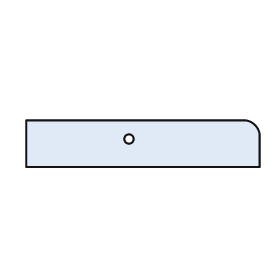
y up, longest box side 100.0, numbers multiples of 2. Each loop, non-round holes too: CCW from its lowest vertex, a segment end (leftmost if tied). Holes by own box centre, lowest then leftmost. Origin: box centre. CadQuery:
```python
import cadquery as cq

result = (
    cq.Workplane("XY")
    .moveTo(-50.0, -10.0)
    .lineTo(50.0, -10.0)
    .lineTo(50.0, 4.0)
    .threePointArc((48.0, 8.0), (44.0, 10.0))
    .lineTo(-50.0, 10.0)
    .close()
    .moveTo(-6.0, 2.0)
    .circle(2.0)
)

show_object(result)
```